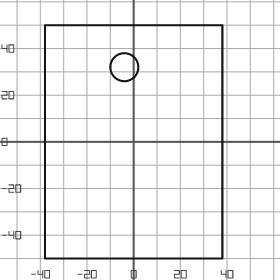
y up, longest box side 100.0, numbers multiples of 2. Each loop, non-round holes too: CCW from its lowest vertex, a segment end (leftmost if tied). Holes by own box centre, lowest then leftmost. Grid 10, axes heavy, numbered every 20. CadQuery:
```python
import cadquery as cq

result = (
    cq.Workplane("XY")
    .moveTo(-38.0, -50.0)
    .lineTo(38.0, -50.0)
    .lineTo(38.0, 50.0)
    .lineTo(-38.0, 50.0)
    .close()
    .moveTo(-4.0, 32.0)
    .circle(6.0)
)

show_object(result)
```